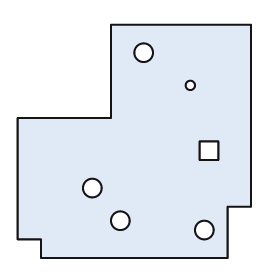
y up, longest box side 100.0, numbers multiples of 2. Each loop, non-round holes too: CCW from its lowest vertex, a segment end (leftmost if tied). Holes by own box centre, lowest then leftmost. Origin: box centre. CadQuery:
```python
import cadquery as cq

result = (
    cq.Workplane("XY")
    .moveTo(-40.0, -50.0)
    .lineTo(40.0, -50.0)
    .lineTo(40.0, -28.0)
    .lineTo(50.0, -28.0)
    .lineTo(50.0, 50.0)
    .lineTo(-10.0, 50.0)
    .lineTo(-10.0, 10.0)
    .lineTo(-50.0, 10.0)
    .lineTo(-50.0, -42.0)
    .lineTo(-40.0, -42.0)
    .close()
    .moveTo(30.0, -38.0)
    .circle(4.0)
    .moveTo(-6.0, -34.0)
    .circle(4.0)
    .moveTo(-18.0, -20.0)
    .circle(4.0)
    .moveTo(28.0, -8.0)
    .lineTo(36.0, -8.0)
    .lineTo(36.0, 0.0)
    .lineTo(28.0, 0.0)
    .close()
    .moveTo(24.0, 24.0)
    .circle(2.0)
    .moveTo(4.0, 38.0)
    .circle(4.0)
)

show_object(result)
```